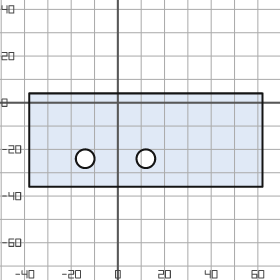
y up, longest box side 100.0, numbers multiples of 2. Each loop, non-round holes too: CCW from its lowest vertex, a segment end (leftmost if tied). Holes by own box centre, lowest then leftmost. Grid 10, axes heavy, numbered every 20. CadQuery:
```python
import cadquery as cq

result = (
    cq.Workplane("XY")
    .moveTo(-38.0, -36.0)
    .lineTo(62.0, -36.0)
    .lineTo(62.0, 4.0)
    .lineTo(-38.0, 4.0)
    .close()
    .moveTo(-14.0, -24.0)
    .circle(4.0)
    .moveTo(12.0, -24.0)
    .circle(4.0)
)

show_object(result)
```